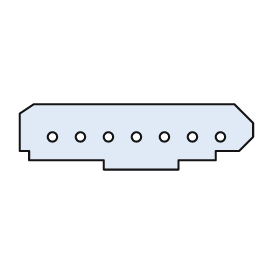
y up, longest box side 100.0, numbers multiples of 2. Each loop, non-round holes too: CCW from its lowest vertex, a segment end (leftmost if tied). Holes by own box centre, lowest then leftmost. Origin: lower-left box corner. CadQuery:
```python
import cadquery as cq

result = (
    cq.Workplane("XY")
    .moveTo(36.0, 0.0)
    .lineTo(68.0, 0.0)
    .lineTo(68.0, 4.0)
    .lineTo(84.0, 4.0)
    .lineTo(84.0, 8.0)
    .lineTo(94.0, 8.0)
    .lineTo(100.0, 14.0)
    .lineTo(100.0, 20.0)
    .lineTo(92.0, 28.0)
    .lineTo(6.0, 28.0)
    .lineTo(0.0, 24.0)
    .lineTo(0.0, 8.0)
    .lineTo(4.0, 8.0)
    .lineTo(4.0, 4.0)
    .lineTo(36.0, 4.0)
    .close()
    .moveTo(14.0, 14.0)
    .circle(2.0)
    .moveTo(26.0, 14.0)
    .circle(2.0)
    .moveTo(38.0, 14.0)
    .circle(2.0)
    .moveTo(50.0, 14.0)
    .circle(2.0)
    .moveTo(62.0, 14.0)
    .circle(2.0)
    .moveTo(74.0, 14.0)
    .circle(2.0)
    .moveTo(86.0, 14.0)
    .circle(2.0)
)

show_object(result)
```